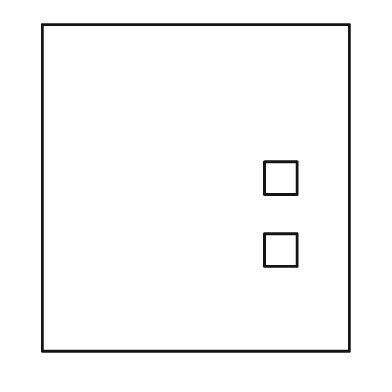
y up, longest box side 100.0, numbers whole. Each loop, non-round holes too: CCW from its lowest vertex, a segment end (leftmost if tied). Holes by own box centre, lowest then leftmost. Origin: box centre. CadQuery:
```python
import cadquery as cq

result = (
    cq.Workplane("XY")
    .moveTo(-47.0, -50.0)
    .lineTo(47.0, -50.0)
    .lineTo(47.0, 50.0)
    .lineTo(-47.0, 50.0)
    .close()
    .moveTo(21.0, -24.0)
    .lineTo(31.0, -24.0)
    .lineTo(31.0, -14.0)
    .lineTo(21.0, -14.0)
    .close()
    .moveTo(21.0, -2.0)
    .lineTo(31.0, -2.0)
    .lineTo(31.0, 8.0)
    .lineTo(21.0, 8.0)
    .close()
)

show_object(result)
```